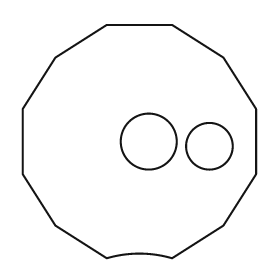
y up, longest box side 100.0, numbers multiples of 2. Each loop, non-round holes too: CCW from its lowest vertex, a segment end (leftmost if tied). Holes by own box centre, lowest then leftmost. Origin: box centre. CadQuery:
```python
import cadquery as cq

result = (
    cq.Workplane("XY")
    .moveTo(-14.0, -50.0)
    .threePointArc((0.0, -48.0), (14.0, -50.0))
    .lineTo(36.0, -36.0)
    .lineTo(50.0, -14.0)
    .lineTo(50.0, 14.0)
    .lineTo(36.0, 36.0)
    .lineTo(14.0, 50.0)
    .lineTo(-14.0, 50.0)
    .lineTo(-36.0, 36.0)
    .lineTo(-50.0, 14.0)
    .lineTo(-50.0, -14.0)
    .lineTo(-36.0, -36.0)
    .close()
    .moveTo(30.0, -2.0)
    .circle(10.0)
    .moveTo(4.0, 0.0)
    .circle(12.0)
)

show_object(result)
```